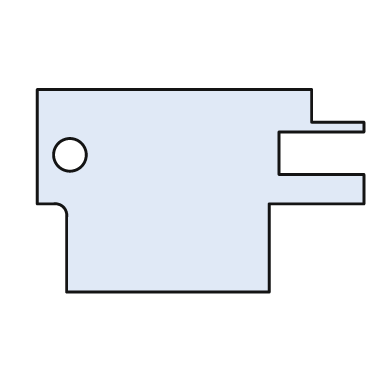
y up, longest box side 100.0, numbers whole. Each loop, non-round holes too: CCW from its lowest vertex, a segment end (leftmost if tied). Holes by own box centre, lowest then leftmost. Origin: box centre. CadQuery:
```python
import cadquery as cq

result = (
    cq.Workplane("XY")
    .moveTo(-41.0, -31.0)
    .lineTo(21.0, -31.0)
    .lineTo(21.0, -4.0)
    .lineTo(50.0, -4.0)
    .lineTo(50.0, 5.0)
    .lineTo(24.0, 5.0)
    .lineTo(24.0, 18.0)
    .lineTo(50.0, 18.0)
    .lineTo(50.0, 21.0)
    .lineTo(34.0, 21.0)
    .lineTo(34.0, 31.0)
    .lineTo(-50.0, 31.0)
    .lineTo(-50.0, -4.0)
    .lineTo(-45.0, -4.0)
    .threePointArc((-42.0, -5.0), (-41.0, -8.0))
    .close()
    .moveTo(-40.0, 11.0)
    .circle(5.0)
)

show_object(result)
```